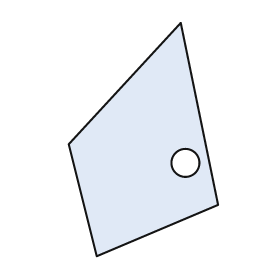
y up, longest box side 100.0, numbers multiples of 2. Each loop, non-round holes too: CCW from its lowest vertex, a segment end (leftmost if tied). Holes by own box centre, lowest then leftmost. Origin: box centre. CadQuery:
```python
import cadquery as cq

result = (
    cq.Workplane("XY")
    .moveTo(-20.0, -50.0)
    .lineTo(32.0, -28.0)
    .lineTo(16.0, 50.0)
    .lineTo(-32.0, -2.0)
    .close()
    .moveTo(18.0, -10.0)
    .circle(6.0)
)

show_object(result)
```